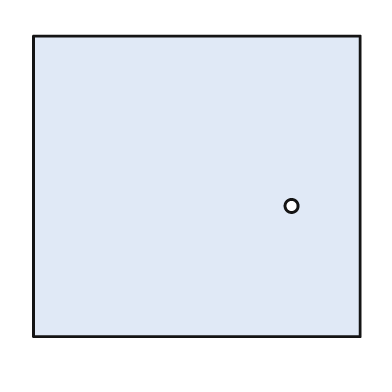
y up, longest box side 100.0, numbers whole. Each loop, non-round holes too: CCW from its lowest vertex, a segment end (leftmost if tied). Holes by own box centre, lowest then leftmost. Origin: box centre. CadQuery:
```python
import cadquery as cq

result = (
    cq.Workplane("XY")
    .moveTo(-50.0, -46.0)
    .lineTo(50.0, -46.0)
    .lineTo(50.0, 46.0)
    .lineTo(-50.0, 46.0)
    .close()
    .moveTo(29.0, -6.0)
    .circle(2.0)
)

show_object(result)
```